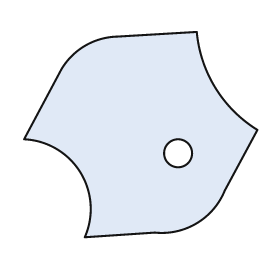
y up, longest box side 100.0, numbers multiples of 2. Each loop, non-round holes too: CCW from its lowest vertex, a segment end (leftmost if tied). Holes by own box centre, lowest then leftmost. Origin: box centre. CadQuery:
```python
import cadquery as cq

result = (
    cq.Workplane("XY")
    .moveTo(-24.0, -44.0)
    .lineTo(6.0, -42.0)
    .threePointArc((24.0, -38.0), (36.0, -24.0))
    .lineTo(50.0, 2.0)
    .threePointArc((32.0, 20.0), (24.0, 44.0))
    .lineTo(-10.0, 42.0)
    .threePointArc((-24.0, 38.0), (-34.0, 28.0))
    .lineTo(-50.0, -2.0)
    .threePointArc((-26.0, -16.0), (-24.0, -44.0))
    .close()
    .moveTo(16.0, -8.0)
    .circle(6.0)
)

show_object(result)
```